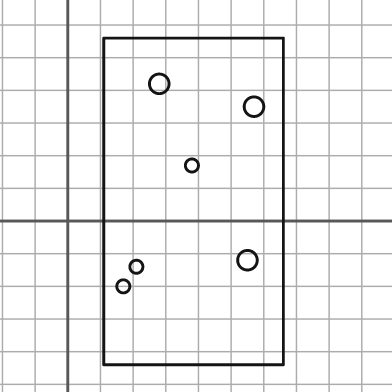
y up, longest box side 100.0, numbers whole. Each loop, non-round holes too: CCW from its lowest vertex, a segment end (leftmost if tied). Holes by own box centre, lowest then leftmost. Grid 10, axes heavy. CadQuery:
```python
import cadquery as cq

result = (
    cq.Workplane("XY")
    .moveTo(11.0, -44.0)
    .lineTo(66.0, -44.0)
    .lineTo(66.0, 56.0)
    .lineTo(11.0, 56.0)
    .close()
    .moveTo(17.0, -20.0)
    .circle(2.0)
    .moveTo(21.0, -14.0)
    .circle(2.0)
    .moveTo(55.0, -12.0)
    .circle(3.0)
    .moveTo(38.0, 17.0)
    .circle(2.0)
    .moveTo(57.0, 35.0)
    .circle(3.0)
    .moveTo(28.0, 42.0)
    .circle(3.0)
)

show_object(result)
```